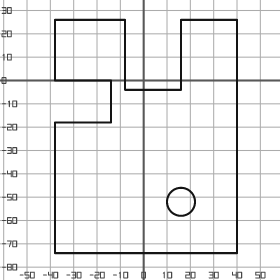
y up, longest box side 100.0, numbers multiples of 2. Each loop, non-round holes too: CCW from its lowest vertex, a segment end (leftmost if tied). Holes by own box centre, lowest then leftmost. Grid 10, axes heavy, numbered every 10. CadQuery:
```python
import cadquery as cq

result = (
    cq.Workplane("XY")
    .moveTo(-38.0, -74.0)
    .lineTo(40.0, -74.0)
    .lineTo(40.0, 26.0)
    .lineTo(16.0, 26.0)
    .lineTo(16.0, -4.0)
    .lineTo(-8.0, -4.0)
    .lineTo(-8.0, 26.0)
    .lineTo(-38.0, 26.0)
    .lineTo(-38.0, 0.0)
    .lineTo(-14.0, 0.0)
    .lineTo(-14.0, -18.0)
    .lineTo(-38.0, -18.0)
    .close()
    .moveTo(16.0, -52.0)
    .circle(6.0)
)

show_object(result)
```